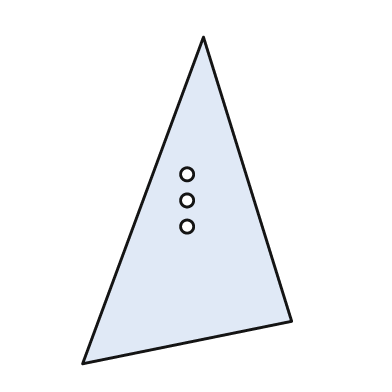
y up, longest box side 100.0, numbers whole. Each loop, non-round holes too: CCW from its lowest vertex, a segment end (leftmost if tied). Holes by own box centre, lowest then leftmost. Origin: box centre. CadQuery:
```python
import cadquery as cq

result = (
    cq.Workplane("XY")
    .moveTo(-32.0, -50.0)
    .lineTo(32.0, -37.0)
    .lineTo(5.0, 50.0)
    .close()
    .moveTo(0.0, -8.0)
    .circle(2.0)
    .moveTo(0.0, 0.0)
    .circle(2.0)
    .moveTo(0.0, 8.0)
    .circle(2.0)
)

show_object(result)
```